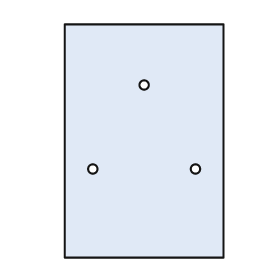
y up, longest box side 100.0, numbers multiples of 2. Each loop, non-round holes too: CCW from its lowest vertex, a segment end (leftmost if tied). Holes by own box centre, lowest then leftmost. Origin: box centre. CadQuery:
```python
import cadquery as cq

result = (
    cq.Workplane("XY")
    .moveTo(-34.0, -50.0)
    .lineTo(34.0, -50.0)
    .lineTo(34.0, 50.0)
    .lineTo(-34.0, 50.0)
    .close()
    .moveTo(-22.0, -12.0)
    .circle(2.0)
    .moveTo(22.0, -12.0)
    .circle(2.0)
    .moveTo(0.0, 24.0)
    .circle(2.0)
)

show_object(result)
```